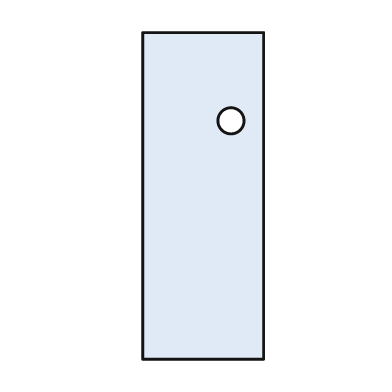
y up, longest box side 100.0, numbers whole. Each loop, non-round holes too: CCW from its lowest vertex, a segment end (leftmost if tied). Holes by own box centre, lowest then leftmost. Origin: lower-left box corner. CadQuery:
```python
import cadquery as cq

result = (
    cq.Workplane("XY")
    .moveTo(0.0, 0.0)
    .lineTo(37.0, 0.0)
    .lineTo(37.0, 100.0)
    .lineTo(0.0, 100.0)
    .close()
    .moveTo(27.0, 73.0)
    .circle(4.0)
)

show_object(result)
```